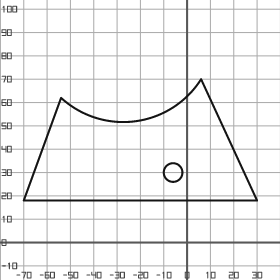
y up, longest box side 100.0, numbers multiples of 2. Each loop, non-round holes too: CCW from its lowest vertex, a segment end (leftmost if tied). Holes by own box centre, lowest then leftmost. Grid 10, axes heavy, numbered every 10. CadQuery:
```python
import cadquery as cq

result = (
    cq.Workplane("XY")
    .moveTo(-70.0, 18.0)
    .lineTo(30.0, 18.0)
    .lineTo(6.0, 70.0)
    .threePointArc((-22.0, 52.0), (-54.0, 62.0))
    .close()
    .moveTo(-6.0, 30.0)
    .circle(4.0)
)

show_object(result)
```